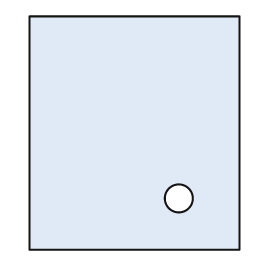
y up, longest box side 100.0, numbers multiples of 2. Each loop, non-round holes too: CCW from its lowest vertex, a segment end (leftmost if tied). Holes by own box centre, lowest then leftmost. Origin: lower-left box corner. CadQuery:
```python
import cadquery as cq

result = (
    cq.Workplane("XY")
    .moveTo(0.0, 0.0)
    .lineTo(90.0, 0.0)
    .lineTo(90.0, 100.0)
    .lineTo(0.0, 100.0)
    .close()
    .moveTo(64.0, 22.0)
    .circle(6.0)
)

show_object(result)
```